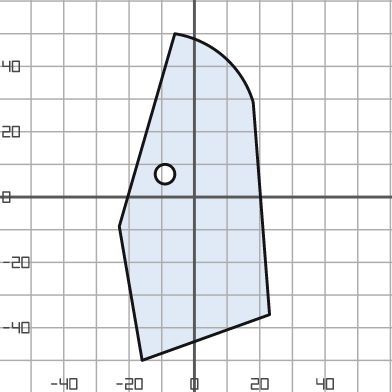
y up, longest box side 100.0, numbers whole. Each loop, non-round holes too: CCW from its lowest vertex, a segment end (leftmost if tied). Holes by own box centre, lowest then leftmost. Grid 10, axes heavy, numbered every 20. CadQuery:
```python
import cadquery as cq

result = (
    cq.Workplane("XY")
    .moveTo(-16.0, -50.0)
    .lineTo(23.0, -36.0)
    .lineTo(18.0, 29.0)
    .threePointArc((9.0, 43.0), (-6.0, 50.0))
    .lineTo(-23.0, -9.0)
    .close()
    .moveTo(-9.0, 7.0)
    .circle(3.0)
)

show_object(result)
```